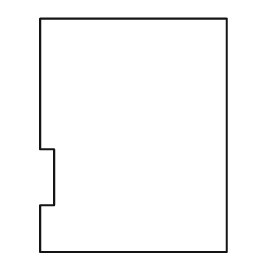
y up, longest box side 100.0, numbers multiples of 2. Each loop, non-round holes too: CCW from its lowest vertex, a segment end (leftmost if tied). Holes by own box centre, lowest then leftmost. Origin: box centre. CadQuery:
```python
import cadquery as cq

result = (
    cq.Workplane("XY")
    .moveTo(-40.0, -50.0)
    .lineTo(40.0, -50.0)
    .lineTo(40.0, 50.0)
    .lineTo(-40.0, 50.0)
    .lineTo(-40.0, -6.0)
    .lineTo(-34.0, -6.0)
    .lineTo(-34.0, -30.0)
    .lineTo(-40.0, -30.0)
    .close()
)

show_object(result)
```